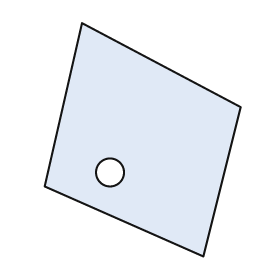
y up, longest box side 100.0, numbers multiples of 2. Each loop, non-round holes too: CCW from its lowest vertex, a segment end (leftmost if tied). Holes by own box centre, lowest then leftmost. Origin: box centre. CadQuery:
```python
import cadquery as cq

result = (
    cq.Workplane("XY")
    .moveTo(26.0, -50.0)
    .lineTo(42.0, 14.0)
    .lineTo(-26.0, 50.0)
    .lineTo(-42.0, -20.0)
    .close()
    .moveTo(-14.0, -14.0)
    .circle(6.0)
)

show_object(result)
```